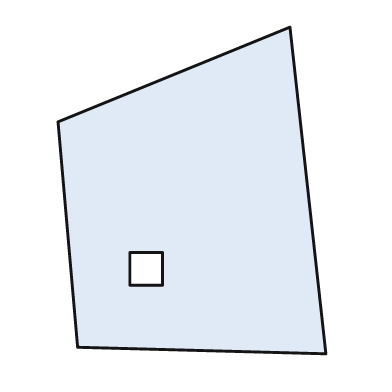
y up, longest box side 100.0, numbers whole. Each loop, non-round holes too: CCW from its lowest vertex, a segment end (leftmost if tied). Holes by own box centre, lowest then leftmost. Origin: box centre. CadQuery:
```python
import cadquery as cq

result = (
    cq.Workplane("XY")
    .moveTo(41.0, -50.0)
    .lineTo(30.0, 50.0)
    .lineTo(-41.0, 21.0)
    .lineTo(-35.0, -48.0)
    .close()
    .moveTo(-19.0, -29.0)
    .lineTo(-9.0, -29.0)
    .lineTo(-9.0, -19.0)
    .lineTo(-19.0, -19.0)
    .close()
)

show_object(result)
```